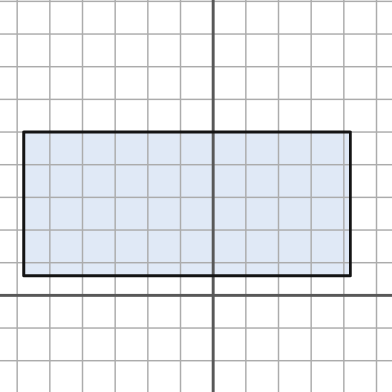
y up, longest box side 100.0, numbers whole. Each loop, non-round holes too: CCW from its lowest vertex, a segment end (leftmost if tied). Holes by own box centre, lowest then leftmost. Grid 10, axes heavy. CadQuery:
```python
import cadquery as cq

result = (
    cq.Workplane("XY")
    .moveTo(-58.0, 6.0)
    .lineTo(42.0, 6.0)
    .lineTo(42.0, 50.0)
    .lineTo(-58.0, 50.0)
    .close()
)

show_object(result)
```